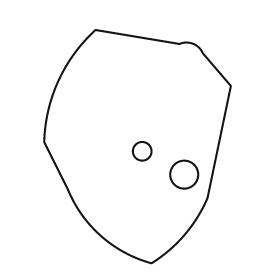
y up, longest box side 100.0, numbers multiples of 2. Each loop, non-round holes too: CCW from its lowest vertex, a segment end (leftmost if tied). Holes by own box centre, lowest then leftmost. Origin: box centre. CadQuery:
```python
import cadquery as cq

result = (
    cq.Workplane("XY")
    .moveTo(6.0, -50.0)
    .threePointArc((20.0, -38.0), (30.0, -22.0))
    .lineTo(40.0, 26.0)
    .lineTo(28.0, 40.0)
    .threePointArc((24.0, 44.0), (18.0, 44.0))
    .lineTo(-18.0, 50.0)
    .threePointArc((-34.0, 28.0), (-40.0, 2.0))
    .lineTo(-30.0, -18.0)
    .threePointArc((-16.0, -38.0), (6.0, -50.0))
    .close()
    .moveTo(20.0, -12.0)
    .circle(6.0)
    .moveTo(2.0, -2.0)
    .circle(4.0)
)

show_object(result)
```